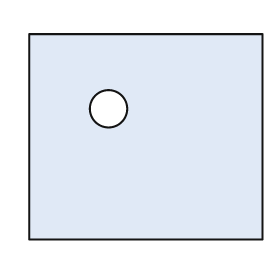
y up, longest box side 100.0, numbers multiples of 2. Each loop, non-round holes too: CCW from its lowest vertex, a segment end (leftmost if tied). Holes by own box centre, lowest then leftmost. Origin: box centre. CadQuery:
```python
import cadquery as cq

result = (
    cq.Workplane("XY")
    .moveTo(-50.0, -44.0)
    .lineTo(50.0, -44.0)
    .lineTo(50.0, 44.0)
    .lineTo(-50.0, 44.0)
    .close()
    .moveTo(-16.0, 12.0)
    .circle(8.0)
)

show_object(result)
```